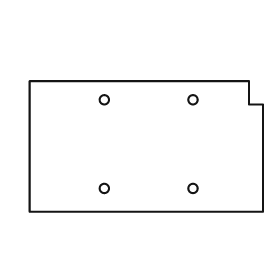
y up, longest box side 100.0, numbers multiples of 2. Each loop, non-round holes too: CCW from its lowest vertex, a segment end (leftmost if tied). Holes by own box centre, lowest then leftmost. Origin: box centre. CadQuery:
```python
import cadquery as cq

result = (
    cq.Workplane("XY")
    .moveTo(-50.0, -28.0)
    .lineTo(50.0, -28.0)
    .lineTo(50.0, 18.0)
    .lineTo(44.0, 18.0)
    .lineTo(44.0, 28.0)
    .lineTo(-50.0, 28.0)
    .close()
    .moveTo(-18.0, -18.0)
    .circle(2.0)
    .moveTo(20.0, -18.0)
    .circle(2.0)
    .moveTo(-18.0, 20.0)
    .circle(2.0)
    .moveTo(20.0, 20.0)
    .circle(2.0)
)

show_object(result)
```